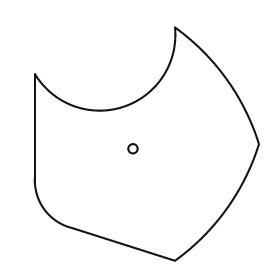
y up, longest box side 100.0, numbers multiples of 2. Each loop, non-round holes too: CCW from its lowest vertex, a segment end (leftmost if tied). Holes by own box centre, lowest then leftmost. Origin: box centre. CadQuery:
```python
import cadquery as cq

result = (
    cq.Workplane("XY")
    .moveTo(12.0, -50.0)
    .threePointArc((34.0, -28.0), (48.0, 0.0))
    .threePointArc((34.0, 28.0), (12.0, 50.0))
    .threePointArc((-10.0, 16.0), (-48.0, 30.0))
    .lineTo(-48.0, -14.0)
    .threePointArc((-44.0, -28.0), (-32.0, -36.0))
    .close()
    .moveTo(-6.0, -2.0)
    .circle(2.0)
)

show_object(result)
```